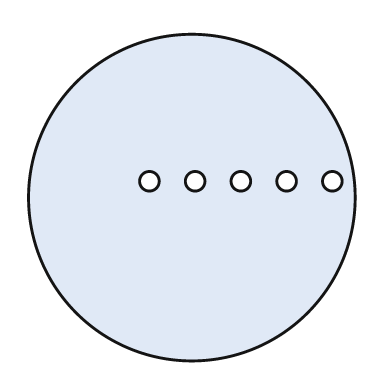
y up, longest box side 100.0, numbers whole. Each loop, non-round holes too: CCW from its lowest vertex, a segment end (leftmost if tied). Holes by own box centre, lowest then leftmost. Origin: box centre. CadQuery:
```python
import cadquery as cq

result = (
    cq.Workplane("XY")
    .moveTo(0.0, 0.0)
    .circle(50.0)
    .moveTo(-13.0, 5.0)
    .circle(3.0)
    .moveTo(1.0, 5.0)
    .circle(3.0)
    .moveTo(15.0, 5.0)
    .circle(3.0)
    .moveTo(29.0, 5.0)
    .circle(3.0)
    .moveTo(43.0, 5.0)
    .circle(3.0)
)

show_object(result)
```